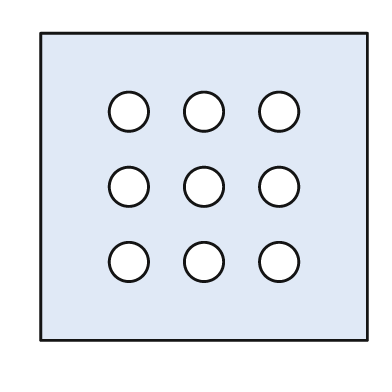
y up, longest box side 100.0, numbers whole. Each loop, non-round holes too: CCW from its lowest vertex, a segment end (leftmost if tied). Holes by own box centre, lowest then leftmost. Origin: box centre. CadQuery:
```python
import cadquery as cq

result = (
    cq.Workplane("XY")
    .moveTo(-50.0, -47.0)
    .lineTo(50.0, -47.0)
    .lineTo(50.0, 47.0)
    .lineTo(-50.0, 47.0)
    .close()
    .moveTo(-23.0, -23.0)
    .circle(6.0)
    .moveTo(0.0, -23.0)
    .circle(6.0)
    .moveTo(23.0, -23.0)
    .circle(6.0)
    .moveTo(-23.0, 0.0)
    .circle(6.0)
    .moveTo(0.0, 0.0)
    .circle(6.0)
    .moveTo(23.0, 0.0)
    .circle(6.0)
    .moveTo(-23.0, 23.0)
    .circle(6.0)
    .moveTo(0.0, 23.0)
    .circle(6.0)
    .moveTo(23.0, 23.0)
    .circle(6.0)
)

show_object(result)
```